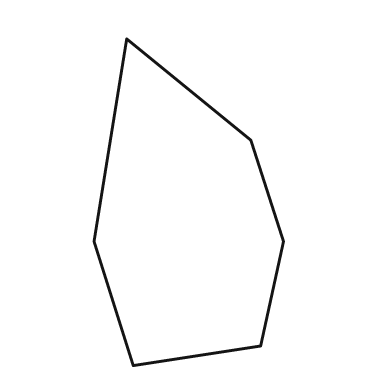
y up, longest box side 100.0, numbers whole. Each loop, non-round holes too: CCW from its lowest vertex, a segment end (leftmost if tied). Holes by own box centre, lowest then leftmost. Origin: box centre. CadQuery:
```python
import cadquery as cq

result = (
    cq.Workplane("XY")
    .moveTo(-17.0, -50.0)
    .lineTo(22.0, -44.0)
    .lineTo(29.0, -12.0)
    .lineTo(19.0, 19.0)
    .lineTo(-19.0, 50.0)
    .lineTo(-29.0, -12.0)
    .close()
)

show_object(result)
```